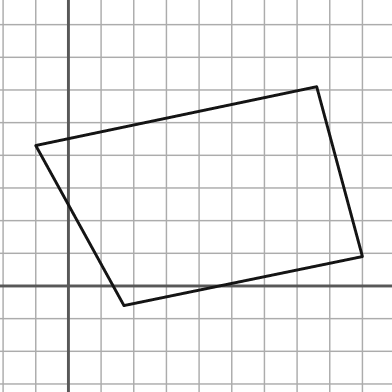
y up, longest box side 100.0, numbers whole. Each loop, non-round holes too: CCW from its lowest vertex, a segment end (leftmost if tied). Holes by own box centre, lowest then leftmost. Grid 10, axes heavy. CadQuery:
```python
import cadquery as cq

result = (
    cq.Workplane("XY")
    .moveTo(17.0, -6.0)
    .lineTo(90.0, 9.0)
    .lineTo(76.0, 61.0)
    .lineTo(-10.0, 43.0)
    .close()
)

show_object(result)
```